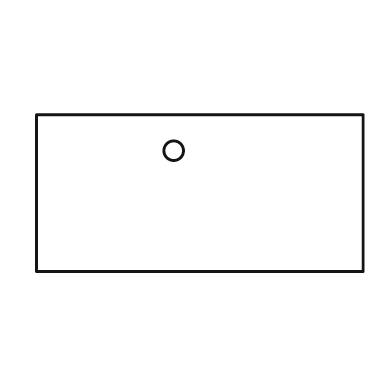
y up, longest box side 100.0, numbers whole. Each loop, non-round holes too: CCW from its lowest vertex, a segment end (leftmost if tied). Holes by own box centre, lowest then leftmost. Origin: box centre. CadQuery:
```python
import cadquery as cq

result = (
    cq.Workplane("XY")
    .moveTo(-50.0, -24.0)
    .lineTo(50.0, -24.0)
    .lineTo(50.0, 24.0)
    .lineTo(-50.0, 24.0)
    .close()
    .moveTo(-8.0, 13.0)
    .circle(3.0)
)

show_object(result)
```